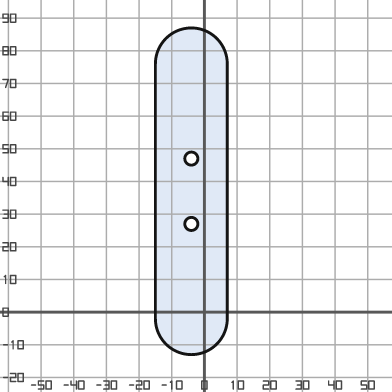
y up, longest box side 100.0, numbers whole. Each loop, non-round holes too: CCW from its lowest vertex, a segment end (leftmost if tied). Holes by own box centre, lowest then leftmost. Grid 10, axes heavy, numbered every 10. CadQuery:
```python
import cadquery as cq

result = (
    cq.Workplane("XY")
    .moveTo(-15.0, -2.0)
    .threePointArc((-4.0, -13.0), (7.0, -2.0))
    .lineTo(7.0, 76.0)
    .threePointArc((-4.0, 87.0), (-15.0, 76.0))
    .close()
    .moveTo(-4.0, 27.0)
    .circle(2.0)
    .moveTo(-4.0, 47.0)
    .circle(2.0)
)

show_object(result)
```